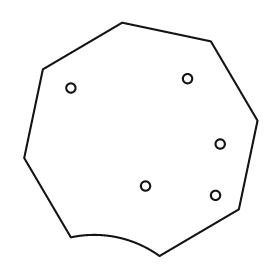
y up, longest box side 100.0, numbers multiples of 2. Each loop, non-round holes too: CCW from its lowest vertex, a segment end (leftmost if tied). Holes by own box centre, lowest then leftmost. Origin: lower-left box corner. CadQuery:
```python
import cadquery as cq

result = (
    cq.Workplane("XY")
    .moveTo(58.0, 0.0)
    .lineTo(92.0, 20.0)
    .lineTo(100.0, 58.0)
    .lineTo(80.0, 92.0)
    .lineTo(42.0, 100.0)
    .lineTo(8.0, 80.0)
    .lineTo(0.0, 42.0)
    .lineTo(20.0, 8.0)
    .threePointArc((40.0, 8.0), (58.0, 0.0))
    .close()
    .moveTo(82.0, 26.0)
    .circle(2.0)
    .moveTo(52.0, 30.0)
    .circle(2.0)
    .moveTo(84.0, 48.0)
    .circle(2.0)
    .moveTo(20.0, 72.0)
    .circle(2.0)
    .moveTo(70.0, 76.0)
    .circle(2.0)
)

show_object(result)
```